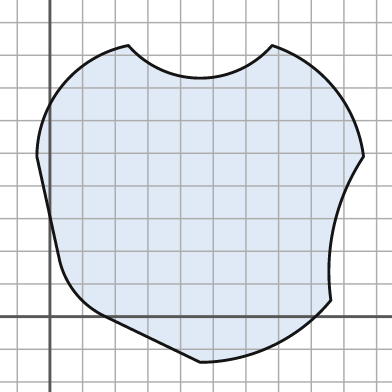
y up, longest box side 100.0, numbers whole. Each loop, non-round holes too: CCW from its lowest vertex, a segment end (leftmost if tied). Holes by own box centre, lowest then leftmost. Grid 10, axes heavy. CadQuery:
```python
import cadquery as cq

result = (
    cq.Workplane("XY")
    .moveTo(46.0, -14.0)
    .threePointArc((68.0, -9.0), (86.0, 5.0))
    .threePointArc((87.0, 28.0), (96.0, 49.0))
    .threePointArc((87.0, 70.0), (68.0, 83.0))
    .threePointArc((46.0, 73.0), (24.0, 83.0))
    .threePointArc((4.0, 71.0), (-4.0, 49.0))
    .lineTo(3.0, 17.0)
    .threePointArc((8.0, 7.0), (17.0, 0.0))
    .close()
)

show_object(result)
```